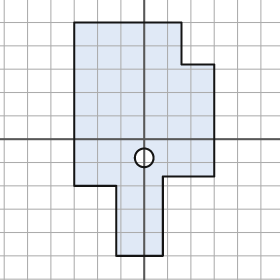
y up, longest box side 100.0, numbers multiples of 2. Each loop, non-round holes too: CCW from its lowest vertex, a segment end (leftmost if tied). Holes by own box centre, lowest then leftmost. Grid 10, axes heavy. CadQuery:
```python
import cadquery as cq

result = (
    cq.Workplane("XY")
    .moveTo(-12.0, -50.0)
    .lineTo(8.0, -50.0)
    .lineTo(8.0, -16.0)
    .lineTo(30.0, -16.0)
    .lineTo(30.0, 32.0)
    .lineTo(16.0, 32.0)
    .lineTo(16.0, 50.0)
    .lineTo(-30.0, 50.0)
    .lineTo(-30.0, -20.0)
    .lineTo(-12.0, -20.0)
    .close()
    .moveTo(0.0, -8.0)
    .circle(4.0)
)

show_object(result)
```